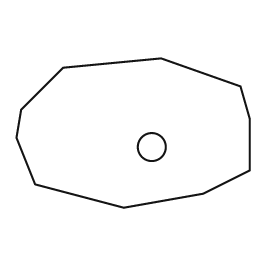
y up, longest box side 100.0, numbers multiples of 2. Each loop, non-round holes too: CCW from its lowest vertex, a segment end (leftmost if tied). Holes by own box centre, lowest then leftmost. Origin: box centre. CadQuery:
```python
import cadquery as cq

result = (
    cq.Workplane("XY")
    .moveTo(-4.0, -32.0)
    .lineTo(30.0, -26.0)
    .lineTo(50.0, -16.0)
    .lineTo(50.0, 6.0)
    .lineTo(46.0, 20.0)
    .lineTo(12.0, 32.0)
    .lineTo(-30.0, 28.0)
    .lineTo(-48.0, 10.0)
    .lineTo(-50.0, -2.0)
    .lineTo(-42.0, -22.0)
    .close()
    .moveTo(8.0, -6.0)
    .circle(6.0)
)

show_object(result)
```